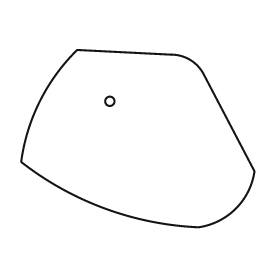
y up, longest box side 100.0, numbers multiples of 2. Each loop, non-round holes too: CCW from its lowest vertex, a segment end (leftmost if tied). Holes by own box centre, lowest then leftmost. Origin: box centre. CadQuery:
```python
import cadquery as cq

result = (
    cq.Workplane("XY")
    .moveTo(26.0, -38.0)
    .threePointArc((42.0, -30.0), (50.0, -14.0))
    .lineTo(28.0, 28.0)
    .threePointArc((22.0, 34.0), (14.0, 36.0))
    .lineTo(-26.0, 38.0)
    .threePointArc((-42.0, 16.0), (-50.0, -10.0))
    .threePointArc((-14.0, -30.0), (26.0, -38.0))
    .close()
    .moveTo(-12.0, 16.0)
    .circle(2.0)
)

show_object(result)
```